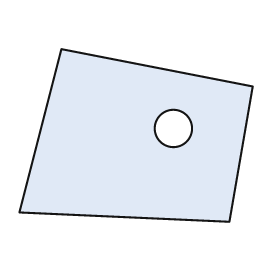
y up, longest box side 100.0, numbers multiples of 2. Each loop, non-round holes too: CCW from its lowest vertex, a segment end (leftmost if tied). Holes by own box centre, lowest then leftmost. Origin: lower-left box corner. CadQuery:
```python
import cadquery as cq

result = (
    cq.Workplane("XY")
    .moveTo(90.0, 0.0)
    .lineTo(100.0, 58.0)
    .lineTo(18.0, 74.0)
    .lineTo(0.0, 4.0)
    .close()
    .moveTo(66.0, 40.0)
    .circle(8.0)
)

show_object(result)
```